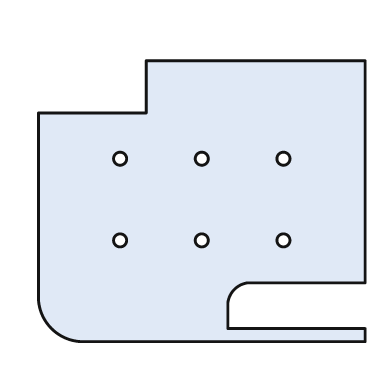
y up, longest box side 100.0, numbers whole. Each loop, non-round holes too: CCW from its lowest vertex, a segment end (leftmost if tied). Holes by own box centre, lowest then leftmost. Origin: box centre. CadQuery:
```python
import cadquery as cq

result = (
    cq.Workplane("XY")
    .moveTo(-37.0, -43.0)
    .lineTo(50.0, -43.0)
    .lineTo(50.0, -39.0)
    .lineTo(8.0, -39.0)
    .lineTo(8.0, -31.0)
    .threePointArc((10.0, -27.0), (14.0, -25.0))
    .lineTo(50.0, -25.0)
    .lineTo(50.0, 43.0)
    .lineTo(-17.0, 43.0)
    .lineTo(-17.0, 27.0)
    .lineTo(-50.0, 27.0)
    .lineTo(-50.0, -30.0)
    .threePointArc((-46.0, -39.0), (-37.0, -43.0))
    .close()
    .moveTo(-25.0, -12.0)
    .circle(2.0)
    .moveTo(0.0, -12.0)
    .circle(2.0)
    .moveTo(25.0, -12.0)
    .circle(2.0)
    .moveTo(-25.0, 13.0)
    .circle(2.0)
    .moveTo(0.0, 13.0)
    .circle(2.0)
    .moveTo(25.0, 13.0)
    .circle(2.0)
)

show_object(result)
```